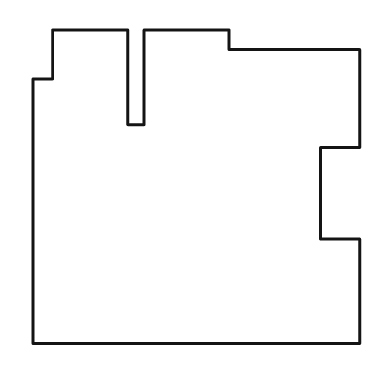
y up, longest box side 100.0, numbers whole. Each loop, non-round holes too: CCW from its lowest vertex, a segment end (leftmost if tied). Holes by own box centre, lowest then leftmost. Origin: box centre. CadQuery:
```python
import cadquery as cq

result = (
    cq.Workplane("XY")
    .moveTo(-50.0, -48.0)
    .lineTo(50.0, -48.0)
    .lineTo(50.0, -16.0)
    .lineTo(38.0, -16.0)
    .lineTo(38.0, 12.0)
    .lineTo(50.0, 12.0)
    .lineTo(50.0, 42.0)
    .lineTo(10.0, 42.0)
    .lineTo(10.0, 48.0)
    .lineTo(-16.0, 48.0)
    .lineTo(-16.0, 19.0)
    .lineTo(-21.0, 19.0)
    .lineTo(-21.0, 48.0)
    .lineTo(-44.0, 48.0)
    .lineTo(-44.0, 33.0)
    .lineTo(-50.0, 33.0)
    .close()
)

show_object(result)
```